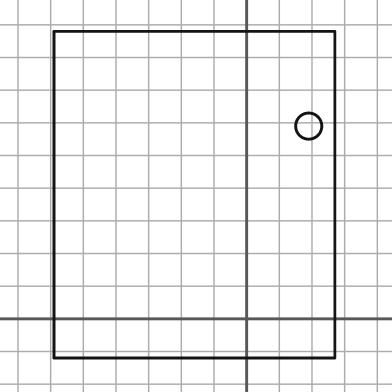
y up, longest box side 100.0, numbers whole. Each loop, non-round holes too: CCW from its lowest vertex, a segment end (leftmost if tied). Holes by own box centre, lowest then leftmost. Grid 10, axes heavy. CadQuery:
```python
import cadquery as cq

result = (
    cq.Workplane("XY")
    .moveTo(-59.0, -12.0)
    .lineTo(27.0, -12.0)
    .lineTo(27.0, 88.0)
    .lineTo(-59.0, 88.0)
    .close()
    .moveTo(19.0, 59.0)
    .circle(4.0)
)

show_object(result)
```